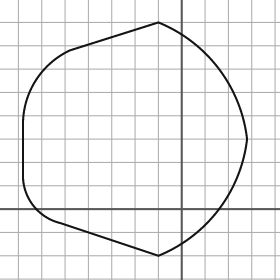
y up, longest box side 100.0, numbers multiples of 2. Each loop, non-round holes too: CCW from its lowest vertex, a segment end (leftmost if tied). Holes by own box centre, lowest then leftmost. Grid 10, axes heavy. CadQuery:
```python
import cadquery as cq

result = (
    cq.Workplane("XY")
    .moveTo(-10.0, -20.0)
    .threePointArc((16.0, 0.0), (28.0, 30.0))
    .threePointArc((16.0, 60.0), (-10.0, 80.0))
    .lineTo(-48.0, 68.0)
    .threePointArc((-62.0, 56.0), (-68.0, 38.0))
    .lineTo(-68.0, 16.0)
    .threePointArc((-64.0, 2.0), (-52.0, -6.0))
    .close()
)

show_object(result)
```